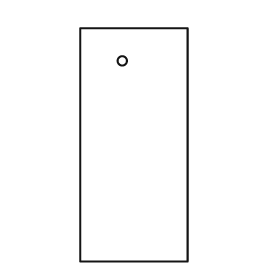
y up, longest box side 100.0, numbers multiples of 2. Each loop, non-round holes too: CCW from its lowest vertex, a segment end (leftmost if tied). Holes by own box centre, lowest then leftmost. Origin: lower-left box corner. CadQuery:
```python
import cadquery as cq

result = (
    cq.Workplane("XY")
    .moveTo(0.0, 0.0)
    .lineTo(46.0, 0.0)
    .lineTo(46.0, 100.0)
    .lineTo(0.0, 100.0)
    .close()
    .moveTo(18.0, 86.0)
    .circle(2.0)
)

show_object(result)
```